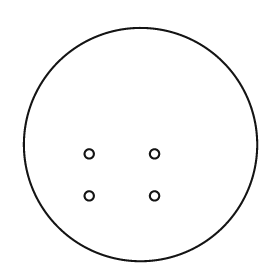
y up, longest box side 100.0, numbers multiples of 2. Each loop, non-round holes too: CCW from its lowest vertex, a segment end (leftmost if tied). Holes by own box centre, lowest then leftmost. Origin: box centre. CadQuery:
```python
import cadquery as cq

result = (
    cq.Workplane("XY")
    .moveTo(0.0, 0.0)
    .circle(50.0)
    .moveTo(-22.0, -22.0)
    .circle(2.0)
    .moveTo(6.0, -22.0)
    .circle(2.0)
    .moveTo(-22.0, -4.0)
    .circle(2.0)
    .moveTo(6.0, -4.0)
    .circle(2.0)
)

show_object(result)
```